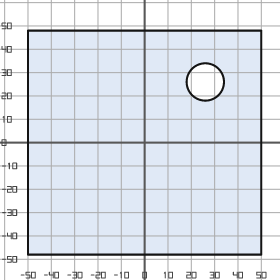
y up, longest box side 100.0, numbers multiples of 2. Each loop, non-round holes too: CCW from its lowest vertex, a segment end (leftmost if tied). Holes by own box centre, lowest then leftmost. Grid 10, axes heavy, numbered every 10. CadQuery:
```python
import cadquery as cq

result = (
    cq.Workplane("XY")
    .moveTo(-50.0, -48.0)
    .lineTo(50.0, -48.0)
    .lineTo(50.0, 48.0)
    .lineTo(-50.0, 48.0)
    .close()
    .moveTo(26.0, 26.0)
    .circle(8.0)
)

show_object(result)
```